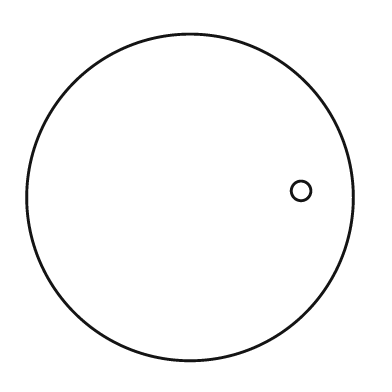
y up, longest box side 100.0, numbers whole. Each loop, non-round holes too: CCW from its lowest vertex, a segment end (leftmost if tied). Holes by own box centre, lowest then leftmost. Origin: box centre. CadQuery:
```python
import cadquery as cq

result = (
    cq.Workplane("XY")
    .moveTo(0.0, 0.0)
    .circle(50.0)
    .moveTo(34.0, 2.0)
    .circle(3.0)
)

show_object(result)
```